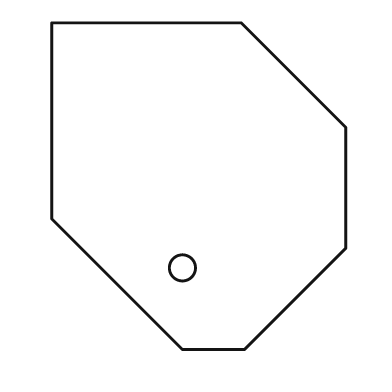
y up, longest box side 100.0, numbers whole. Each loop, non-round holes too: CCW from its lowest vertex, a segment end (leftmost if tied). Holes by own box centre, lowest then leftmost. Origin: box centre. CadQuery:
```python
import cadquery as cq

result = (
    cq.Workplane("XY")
    .moveTo(-5.0, -50.0)
    .lineTo(14.0, -50.0)
    .lineTo(45.0, -19.0)
    .lineTo(45.0, 18.0)
    .lineTo(13.0, 50.0)
    .lineTo(-45.0, 50.0)
    .lineTo(-45.0, -10.0)
    .close()
    .moveTo(-5.0, -25.0)
    .circle(4.0)
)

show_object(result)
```